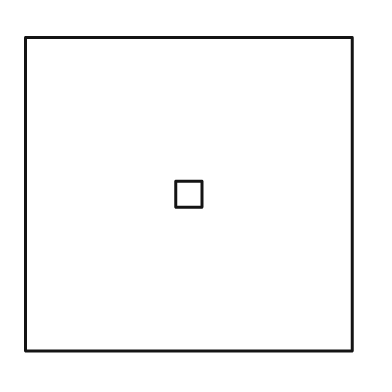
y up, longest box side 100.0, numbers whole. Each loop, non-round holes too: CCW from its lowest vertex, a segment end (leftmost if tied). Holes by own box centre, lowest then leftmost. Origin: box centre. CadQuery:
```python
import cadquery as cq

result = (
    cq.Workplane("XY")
    .moveTo(-50.0, -48.0)
    .lineTo(50.0, -48.0)
    .lineTo(50.0, 48.0)
    .lineTo(-50.0, 48.0)
    .close()
    .moveTo(-4.0, -4.0)
    .lineTo(4.0, -4.0)
    .lineTo(4.0, 4.0)
    .lineTo(-4.0, 4.0)
    .close()
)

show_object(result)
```